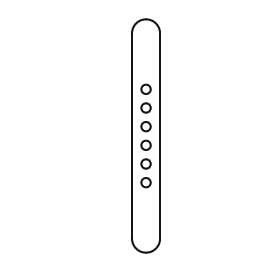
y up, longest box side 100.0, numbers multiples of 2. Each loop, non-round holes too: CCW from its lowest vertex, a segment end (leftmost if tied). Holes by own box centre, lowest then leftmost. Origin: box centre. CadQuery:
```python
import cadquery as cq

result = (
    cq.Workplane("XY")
    .moveTo(-6.0, -44.0)
    .threePointArc((0.0, -50.0), (6.0, -44.0))
    .lineTo(6.0, 44.0)
    .threePointArc((0.0, 50.0), (-6.0, 44.0))
    .close()
    .moveTo(0.0, -20.0)
    .circle(2.0)
    .moveTo(0.0, -12.0)
    .circle(2.0)
    .moveTo(0.0, -4.0)
    .circle(2.0)
    .moveTo(0.0, 4.0)
    .circle(2.0)
    .moveTo(0.0, 12.0)
    .circle(2.0)
    .moveTo(0.0, 20.0)
    .circle(2.0)
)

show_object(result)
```